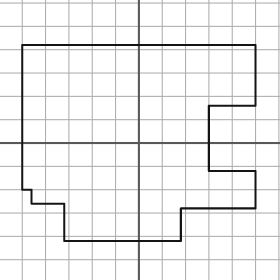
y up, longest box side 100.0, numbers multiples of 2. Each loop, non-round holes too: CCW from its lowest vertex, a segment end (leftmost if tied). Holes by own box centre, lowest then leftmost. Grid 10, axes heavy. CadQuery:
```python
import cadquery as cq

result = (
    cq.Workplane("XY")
    .moveTo(-32.0, -42.0)
    .lineTo(18.0, -42.0)
    .lineTo(18.0, -28.0)
    .lineTo(50.0, -28.0)
    .lineTo(50.0, -12.0)
    .lineTo(30.0, -12.0)
    .lineTo(30.0, 16.0)
    .lineTo(50.0, 16.0)
    .lineTo(50.0, 42.0)
    .lineTo(-50.0, 42.0)
    .lineTo(-50.0, -20.0)
    .lineTo(-46.0, -20.0)
    .lineTo(-46.0, -26.0)
    .lineTo(-32.0, -26.0)
    .close()
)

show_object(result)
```